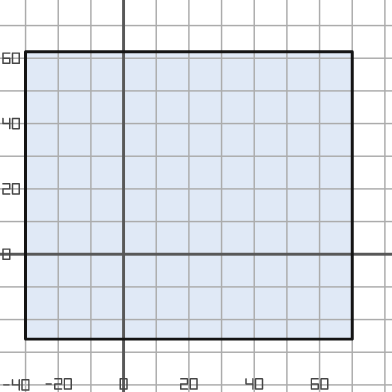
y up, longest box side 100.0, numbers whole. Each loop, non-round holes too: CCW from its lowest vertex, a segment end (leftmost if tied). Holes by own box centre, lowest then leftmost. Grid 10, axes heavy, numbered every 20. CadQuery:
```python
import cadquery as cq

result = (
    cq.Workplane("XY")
    .moveTo(-30.0, -26.0)
    .lineTo(70.0, -26.0)
    .lineTo(70.0, 62.0)
    .lineTo(-30.0, 62.0)
    .close()
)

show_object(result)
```